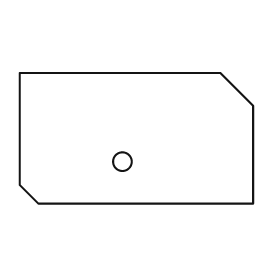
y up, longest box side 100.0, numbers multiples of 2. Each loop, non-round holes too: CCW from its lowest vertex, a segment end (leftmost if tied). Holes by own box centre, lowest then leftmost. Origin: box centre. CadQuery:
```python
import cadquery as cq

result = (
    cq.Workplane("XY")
    .moveTo(-42.0, -28.0)
    .lineTo(50.0, -28.0)
    .lineTo(50.0, 14.0)
    .lineTo(36.0, 28.0)
    .lineTo(-50.0, 28.0)
    .lineTo(-50.0, -20.0)
    .close()
    .moveTo(-6.0, -10.0)
    .circle(4.0)
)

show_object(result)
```